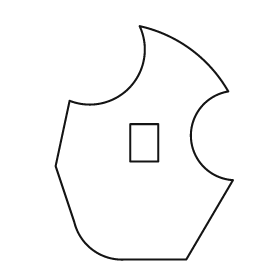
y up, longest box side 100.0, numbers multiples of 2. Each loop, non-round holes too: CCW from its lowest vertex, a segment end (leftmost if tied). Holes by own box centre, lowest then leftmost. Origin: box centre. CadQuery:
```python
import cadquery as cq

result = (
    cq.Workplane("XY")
    .moveTo(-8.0, -50.0)
    .lineTo(18.0, -50.0)
    .lineTo(38.0, -16.0)
    .threePointArc((20.0, 2.0), (36.0, 22.0))
    .threePointArc((20.0, 40.0), (-2.0, 50.0))
    .threePointArc((-6.0, 24.0), (-32.0, 18.0))
    .lineTo(-38.0, -10.0)
    .lineTo(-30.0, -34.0)
    .threePointArc((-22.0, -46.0), (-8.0, -50.0))
    .close()
    .moveTo(-6.0, -8.0)
    .lineTo(6.0, -8.0)
    .lineTo(6.0, 8.0)
    .lineTo(-6.0, 8.0)
    .close()
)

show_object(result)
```